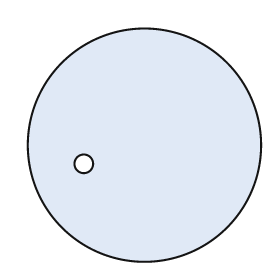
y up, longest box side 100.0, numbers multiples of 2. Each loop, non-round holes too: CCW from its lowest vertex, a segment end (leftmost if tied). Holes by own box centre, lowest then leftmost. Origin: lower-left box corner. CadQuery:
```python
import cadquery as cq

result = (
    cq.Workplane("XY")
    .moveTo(50.0, 50.0)
    .circle(50.0)
    .moveTo(24.0, 42.0)
    .circle(4.0)
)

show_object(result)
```